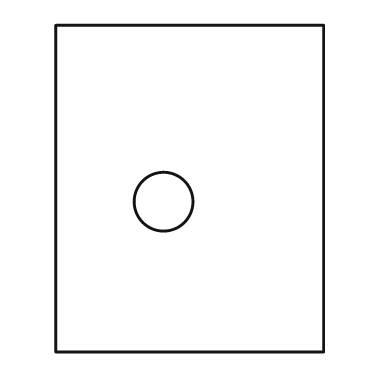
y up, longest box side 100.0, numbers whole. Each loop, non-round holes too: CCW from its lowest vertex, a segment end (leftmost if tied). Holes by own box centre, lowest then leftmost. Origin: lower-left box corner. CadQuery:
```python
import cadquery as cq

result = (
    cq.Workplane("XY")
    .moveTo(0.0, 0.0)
    .lineTo(82.0, 0.0)
    .lineTo(82.0, 100.0)
    .lineTo(0.0, 100.0)
    .close()
    .moveTo(33.0, 46.0)
    .circle(9.0)
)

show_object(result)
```